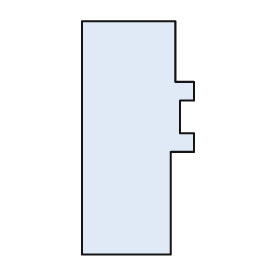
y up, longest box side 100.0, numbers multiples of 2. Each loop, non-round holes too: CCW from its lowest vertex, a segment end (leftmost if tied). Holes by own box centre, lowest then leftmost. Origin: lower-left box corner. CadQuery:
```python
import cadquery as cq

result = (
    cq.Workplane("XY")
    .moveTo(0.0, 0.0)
    .lineTo(38.0, 0.0)
    .lineTo(38.0, 44.0)
    .lineTo(48.0, 44.0)
    .lineTo(48.0, 52.0)
    .lineTo(42.0, 52.0)
    .lineTo(42.0, 66.0)
    .lineTo(48.0, 66.0)
    .lineTo(48.0, 74.0)
    .lineTo(40.0, 74.0)
    .lineTo(40.0, 100.0)
    .lineTo(0.0, 100.0)
    .close()
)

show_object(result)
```